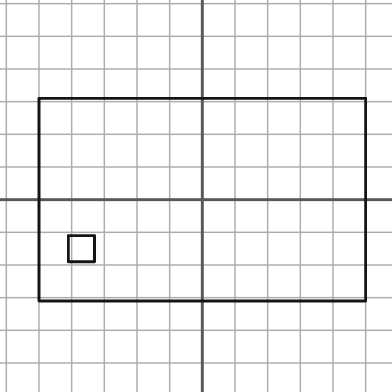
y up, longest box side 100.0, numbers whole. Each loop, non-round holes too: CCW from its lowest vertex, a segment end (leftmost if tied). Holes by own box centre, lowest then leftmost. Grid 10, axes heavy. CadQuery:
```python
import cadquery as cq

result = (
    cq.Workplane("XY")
    .moveTo(-50.0, -31.0)
    .lineTo(50.0, -31.0)
    .lineTo(50.0, 31.0)
    .lineTo(-50.0, 31.0)
    .close()
    .moveTo(-41.0, -19.0)
    .lineTo(-33.0, -19.0)
    .lineTo(-33.0, -11.0)
    .lineTo(-41.0, -11.0)
    .close()
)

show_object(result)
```